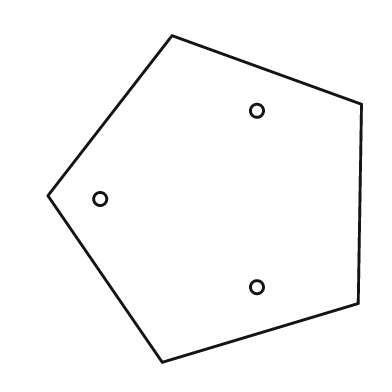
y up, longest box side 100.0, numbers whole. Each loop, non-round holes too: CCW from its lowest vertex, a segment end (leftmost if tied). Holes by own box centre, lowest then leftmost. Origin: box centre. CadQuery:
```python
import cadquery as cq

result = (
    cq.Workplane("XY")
    .moveTo(-13.0, -50.0)
    .lineTo(47.0, -32.0)
    .lineTo(48.0, 29.0)
    .lineTo(-10.0, 50.0)
    .lineTo(-48.0, 1.0)
    .close()
    .moveTo(16.0, -27.0)
    .circle(2.0)
    .moveTo(-32.0, 0.0)
    .circle(2.0)
    .moveTo(16.0, 27.0)
    .circle(2.0)
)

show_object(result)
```